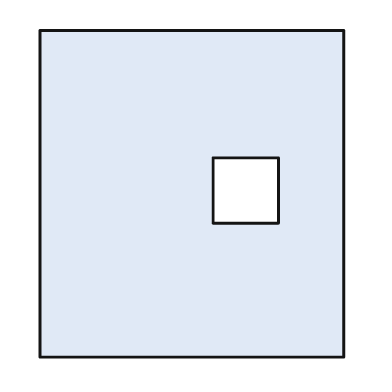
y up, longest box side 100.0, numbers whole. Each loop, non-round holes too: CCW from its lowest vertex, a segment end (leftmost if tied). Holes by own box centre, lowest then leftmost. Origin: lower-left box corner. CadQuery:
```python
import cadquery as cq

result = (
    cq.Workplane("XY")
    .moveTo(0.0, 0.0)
    .lineTo(93.0, 0.0)
    .lineTo(93.0, 100.0)
    .lineTo(0.0, 100.0)
    .close()
    .moveTo(53.0, 41.0)
    .lineTo(73.0, 41.0)
    .lineTo(73.0, 61.0)
    .lineTo(53.0, 61.0)
    .close()
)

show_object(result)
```